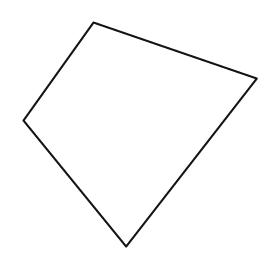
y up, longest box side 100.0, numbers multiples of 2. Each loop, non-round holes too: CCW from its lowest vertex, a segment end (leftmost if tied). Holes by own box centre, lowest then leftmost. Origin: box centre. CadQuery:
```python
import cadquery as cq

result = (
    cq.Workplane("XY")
    .moveTo(-6.0, -48.0)
    .lineTo(50.0, 24.0)
    .lineTo(-20.0, 48.0)
    .lineTo(-50.0, 6.0)
    .close()
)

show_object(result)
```